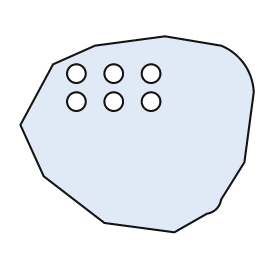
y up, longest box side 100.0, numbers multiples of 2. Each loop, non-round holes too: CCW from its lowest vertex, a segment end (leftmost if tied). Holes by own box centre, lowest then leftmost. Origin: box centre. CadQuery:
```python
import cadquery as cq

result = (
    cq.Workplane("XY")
    .moveTo(16.0, -42.0)
    .lineTo(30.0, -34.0)
    .threePointArc((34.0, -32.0), (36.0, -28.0))
    .lineTo(46.0, -12.0)
    .lineTo(50.0, 18.0)
    .threePointArc((46.0, 30.0), (36.0, 38.0))
    .lineTo(12.0, 42.0)
    .lineTo(-18.0, 38.0)
    .lineTo(-36.0, 30.0)
    .lineTo(-50.0, 4.0)
    .lineTo(-40.0, -18.0)
    .lineTo(-14.0, -38.0)
    .close()
    .moveTo(-26.0, 14.0)
    .circle(4.0)
    .moveTo(-10.0, 14.0)
    .circle(4.0)
    .moveTo(6.0, 14.0)
    .circle(4.0)
    .moveTo(-26.0, 26.0)
    .circle(4.0)
    .moveTo(-10.0, 26.0)
    .circle(4.0)
    .moveTo(6.0, 26.0)
    .circle(4.0)
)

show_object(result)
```